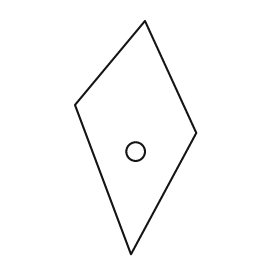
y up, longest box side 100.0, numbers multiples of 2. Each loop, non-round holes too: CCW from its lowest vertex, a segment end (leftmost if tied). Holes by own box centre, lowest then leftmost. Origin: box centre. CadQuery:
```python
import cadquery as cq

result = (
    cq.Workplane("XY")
    .moveTo(-2.0, -50.0)
    .lineTo(26.0, 2.0)
    .lineTo(4.0, 50.0)
    .lineTo(-26.0, 14.0)
    .close()
    .moveTo(0.0, -6.0)
    .circle(4.0)
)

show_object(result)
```